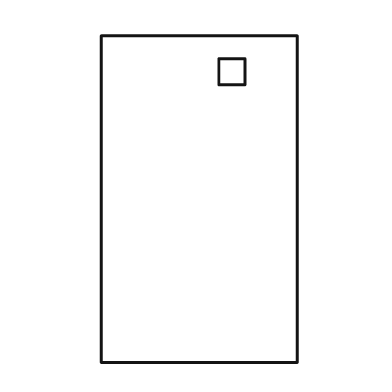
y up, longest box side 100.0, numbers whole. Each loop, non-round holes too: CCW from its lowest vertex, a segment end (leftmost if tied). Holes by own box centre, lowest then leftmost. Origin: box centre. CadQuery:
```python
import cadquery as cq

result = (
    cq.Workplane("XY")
    .moveTo(-30.0, -50.0)
    .lineTo(30.0, -50.0)
    .lineTo(30.0, 50.0)
    .lineTo(-30.0, 50.0)
    .close()
    .moveTo(6.0, 35.0)
    .lineTo(14.0, 35.0)
    .lineTo(14.0, 43.0)
    .lineTo(6.0, 43.0)
    .close()
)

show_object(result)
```